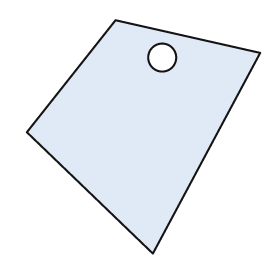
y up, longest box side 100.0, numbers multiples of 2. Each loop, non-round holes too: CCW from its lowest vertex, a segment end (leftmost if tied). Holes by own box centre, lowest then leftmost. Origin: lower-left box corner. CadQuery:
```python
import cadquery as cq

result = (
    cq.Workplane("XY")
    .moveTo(54.0, 0.0)
    .lineTo(100.0, 86.0)
    .lineTo(38.0, 100.0)
    .lineTo(0.0, 52.0)
    .close()
    .moveTo(58.0, 84.0)
    .circle(6.0)
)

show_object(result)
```